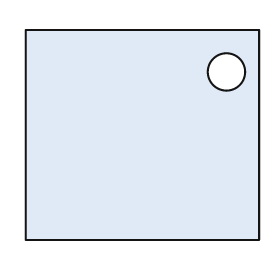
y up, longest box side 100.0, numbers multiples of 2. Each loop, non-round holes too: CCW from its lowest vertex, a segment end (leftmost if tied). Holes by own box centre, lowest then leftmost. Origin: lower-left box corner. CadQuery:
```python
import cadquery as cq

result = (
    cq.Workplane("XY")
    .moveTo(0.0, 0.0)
    .lineTo(100.0, 0.0)
    .lineTo(100.0, 90.0)
    .lineTo(0.0, 90.0)
    .close()
    .moveTo(86.0, 72.0)
    .circle(8.0)
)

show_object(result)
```